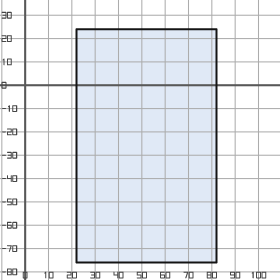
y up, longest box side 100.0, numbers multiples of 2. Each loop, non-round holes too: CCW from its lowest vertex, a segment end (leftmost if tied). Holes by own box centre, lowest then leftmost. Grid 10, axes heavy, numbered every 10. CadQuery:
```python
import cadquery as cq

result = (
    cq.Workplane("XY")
    .moveTo(22.0, -76.0)
    .lineTo(82.0, -76.0)
    .lineTo(82.0, 24.0)
    .lineTo(22.0, 24.0)
    .close()
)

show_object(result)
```